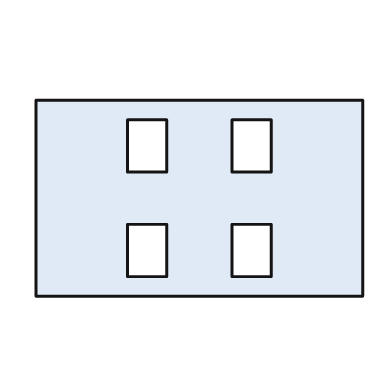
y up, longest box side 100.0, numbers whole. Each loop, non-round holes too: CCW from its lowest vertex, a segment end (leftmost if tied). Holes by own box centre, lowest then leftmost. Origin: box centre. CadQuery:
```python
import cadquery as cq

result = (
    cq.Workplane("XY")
    .moveTo(-50.0, -30.0)
    .lineTo(50.0, -30.0)
    .lineTo(50.0, 30.0)
    .lineTo(-50.0, 30.0)
    .close()
    .moveTo(-22.0, -24.0)
    .lineTo(-10.0, -24.0)
    .lineTo(-10.0, -8.0)
    .lineTo(-22.0, -8.0)
    .close()
    .moveTo(10.0, -24.0)
    .lineTo(22.0, -24.0)
    .lineTo(22.0, -8.0)
    .lineTo(10.0, -8.0)
    .close()
    .moveTo(-22.0, 8.0)
    .lineTo(-10.0, 8.0)
    .lineTo(-10.0, 24.0)
    .lineTo(-22.0, 24.0)
    .close()
    .moveTo(10.0, 8.0)
    .lineTo(22.0, 8.0)
    .lineTo(22.0, 24.0)
    .lineTo(10.0, 24.0)
    .close()
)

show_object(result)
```